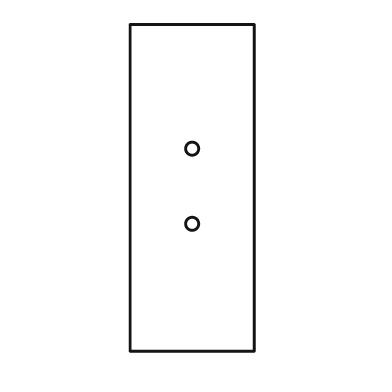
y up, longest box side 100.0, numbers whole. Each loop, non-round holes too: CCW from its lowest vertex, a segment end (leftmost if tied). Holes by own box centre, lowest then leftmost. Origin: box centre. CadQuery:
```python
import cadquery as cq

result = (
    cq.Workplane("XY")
    .moveTo(-19.0, -50.0)
    .lineTo(19.0, -50.0)
    .lineTo(19.0, 50.0)
    .lineTo(-19.0, 50.0)
    .close()
    .moveTo(0.0, -11.0)
    .circle(2.0)
    .moveTo(0.0, 12.0)
    .circle(2.0)
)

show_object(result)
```